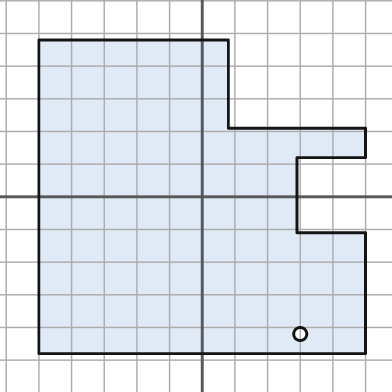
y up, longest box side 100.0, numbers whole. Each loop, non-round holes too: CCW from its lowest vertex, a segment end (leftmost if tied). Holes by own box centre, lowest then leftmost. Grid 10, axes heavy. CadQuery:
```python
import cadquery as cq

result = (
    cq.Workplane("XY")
    .moveTo(-50.0, -48.0)
    .lineTo(50.0, -48.0)
    .lineTo(50.0, -11.0)
    .lineTo(29.0, -11.0)
    .lineTo(29.0, 12.0)
    .lineTo(50.0, 12.0)
    .lineTo(50.0, 21.0)
    .lineTo(8.0, 21.0)
    .lineTo(8.0, 48.0)
    .lineTo(-50.0, 48.0)
    .close()
    .moveTo(30.0, -42.0)
    .circle(2.0)
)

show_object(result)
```